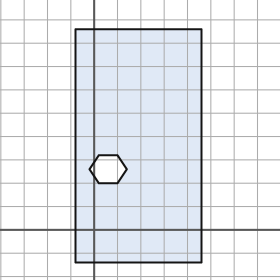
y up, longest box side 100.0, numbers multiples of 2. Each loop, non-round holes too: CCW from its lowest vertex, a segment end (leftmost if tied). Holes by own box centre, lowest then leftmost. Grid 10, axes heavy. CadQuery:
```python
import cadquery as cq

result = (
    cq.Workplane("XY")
    .moveTo(-8.0, -14.0)
    .lineTo(46.0, -14.0)
    .lineTo(46.0, 86.0)
    .lineTo(-8.0, 86.0)
    .close()
    .moveTo(2.0, 20.0)
    .lineTo(10.0, 20.0)
    .lineTo(14.0, 26.0)
    .lineTo(10.0, 32.0)
    .lineTo(2.0, 32.0)
    .lineTo(-2.0, 26.0)
    .close()
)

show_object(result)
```